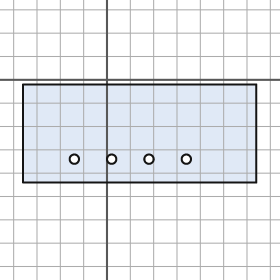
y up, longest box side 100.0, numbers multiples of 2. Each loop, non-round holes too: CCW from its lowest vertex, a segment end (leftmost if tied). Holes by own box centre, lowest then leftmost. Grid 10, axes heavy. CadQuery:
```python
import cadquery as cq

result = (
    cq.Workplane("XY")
    .moveTo(-36.0, -44.0)
    .lineTo(64.0, -44.0)
    .lineTo(64.0, -2.0)
    .lineTo(-36.0, -2.0)
    .close()
    .moveTo(-14.0, -34.0)
    .circle(2.0)
    .moveTo(2.0, -34.0)
    .circle(2.0)
    .moveTo(18.0, -34.0)
    .circle(2.0)
    .moveTo(34.0, -34.0)
    .circle(2.0)
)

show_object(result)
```